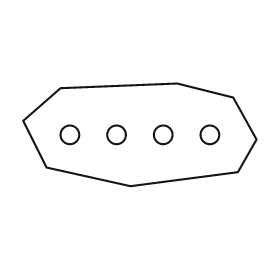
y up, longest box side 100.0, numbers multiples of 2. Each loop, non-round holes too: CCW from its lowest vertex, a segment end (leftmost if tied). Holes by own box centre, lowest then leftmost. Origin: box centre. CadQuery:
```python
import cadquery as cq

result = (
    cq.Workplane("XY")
    .moveTo(-4.0, -22.0)
    .lineTo(42.0, -16.0)
    .lineTo(50.0, -2.0)
    .lineTo(40.0, 16.0)
    .lineTo(16.0, 22.0)
    .lineTo(-34.0, 20.0)
    .lineTo(-50.0, 6.0)
    .lineTo(-40.0, -14.0)
    .close()
    .moveTo(-30.0, 0.0)
    .circle(4.0)
    .moveTo(-10.0, 0.0)
    .circle(4.0)
    .moveTo(10.0, 0.0)
    .circle(4.0)
    .moveTo(30.0, 0.0)
    .circle(4.0)
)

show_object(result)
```